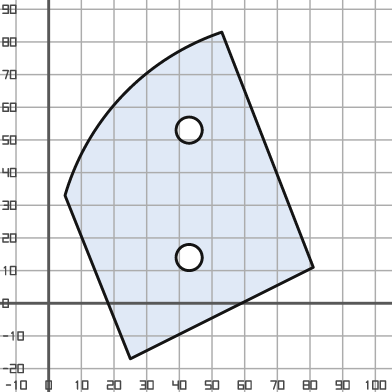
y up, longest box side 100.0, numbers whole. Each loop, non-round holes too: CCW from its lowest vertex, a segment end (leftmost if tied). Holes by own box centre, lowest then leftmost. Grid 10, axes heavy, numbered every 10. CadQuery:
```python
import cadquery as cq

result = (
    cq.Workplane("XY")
    .moveTo(25.0, -17.0)
    .lineTo(81.0, 11.0)
    .lineTo(53.0, 83.0)
    .threePointArc((23.0, 64.0), (5.0, 33.0))
    .close()
    .moveTo(43.0, 14.0)
    .circle(4.0)
    .moveTo(43.0, 53.0)
    .circle(4.0)
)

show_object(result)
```